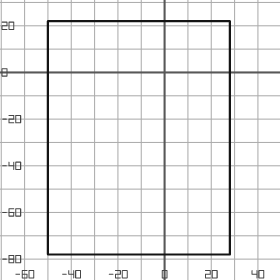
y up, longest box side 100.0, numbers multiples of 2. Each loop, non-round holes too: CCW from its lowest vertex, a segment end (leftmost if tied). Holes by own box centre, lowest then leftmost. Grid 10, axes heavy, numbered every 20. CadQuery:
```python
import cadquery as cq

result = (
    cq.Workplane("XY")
    .moveTo(-50.0, -78.0)
    .lineTo(28.0, -78.0)
    .lineTo(28.0, 22.0)
    .lineTo(-50.0, 22.0)
    .close()
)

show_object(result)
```